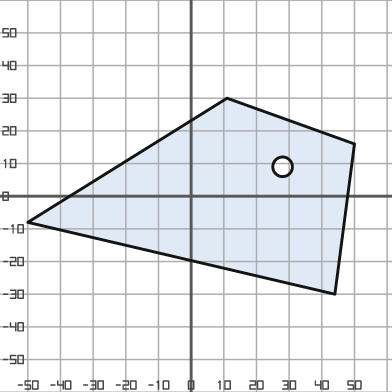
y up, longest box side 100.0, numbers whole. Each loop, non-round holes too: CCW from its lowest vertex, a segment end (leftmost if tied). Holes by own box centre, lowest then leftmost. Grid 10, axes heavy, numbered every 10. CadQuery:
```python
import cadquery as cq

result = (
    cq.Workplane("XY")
    .moveTo(44.0, -30.0)
    .lineTo(50.0, 16.0)
    .lineTo(11.0, 30.0)
    .lineTo(-50.0, -8.0)
    .close()
    .moveTo(28.0, 9.0)
    .circle(3.0)
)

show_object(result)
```